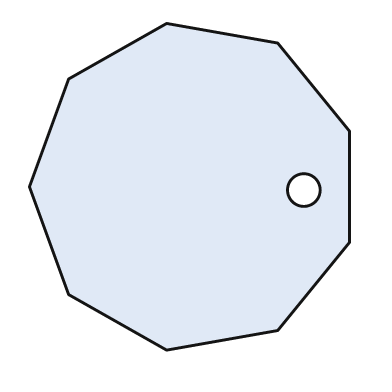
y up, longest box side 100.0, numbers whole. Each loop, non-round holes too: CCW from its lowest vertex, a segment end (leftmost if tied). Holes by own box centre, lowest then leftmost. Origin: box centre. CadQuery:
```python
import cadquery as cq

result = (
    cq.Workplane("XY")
    .moveTo(-7.0, -50.0)
    .lineTo(27.0, -44.0)
    .lineTo(49.0, -17.0)
    .lineTo(49.0, 17.0)
    .lineTo(27.0, 44.0)
    .lineTo(-7.0, 50.0)
    .lineTo(-37.0, 33.0)
    .lineTo(-49.0, 0.0)
    .lineTo(-37.0, -33.0)
    .close()
    .moveTo(35.0, -1.0)
    .circle(5.0)
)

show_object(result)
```